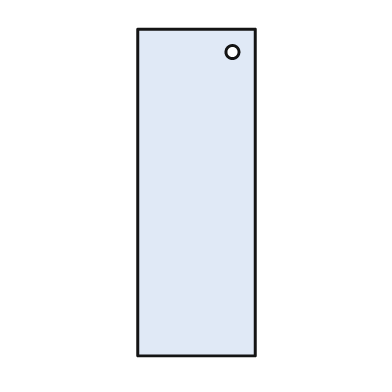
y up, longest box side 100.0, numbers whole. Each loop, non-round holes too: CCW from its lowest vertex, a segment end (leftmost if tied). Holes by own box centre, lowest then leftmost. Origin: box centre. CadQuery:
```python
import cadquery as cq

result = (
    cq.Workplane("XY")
    .moveTo(-18.0, -50.0)
    .lineTo(18.0, -50.0)
    .lineTo(18.0, 50.0)
    .lineTo(-18.0, 50.0)
    .close()
    .moveTo(11.0, 43.0)
    .circle(2.0)
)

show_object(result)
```